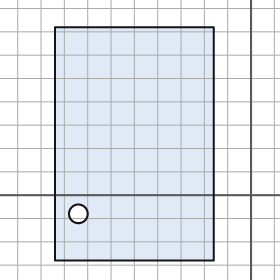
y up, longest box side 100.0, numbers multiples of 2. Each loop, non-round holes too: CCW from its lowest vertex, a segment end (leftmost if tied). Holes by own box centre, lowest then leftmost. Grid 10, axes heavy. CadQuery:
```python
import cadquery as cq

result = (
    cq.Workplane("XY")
    .moveTo(-84.0, -28.0)
    .lineTo(-16.0, -28.0)
    .lineTo(-16.0, 72.0)
    .lineTo(-84.0, 72.0)
    .close()
    .moveTo(-74.0, -8.0)
    .circle(4.0)
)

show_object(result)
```